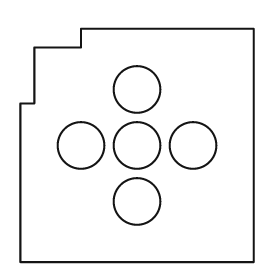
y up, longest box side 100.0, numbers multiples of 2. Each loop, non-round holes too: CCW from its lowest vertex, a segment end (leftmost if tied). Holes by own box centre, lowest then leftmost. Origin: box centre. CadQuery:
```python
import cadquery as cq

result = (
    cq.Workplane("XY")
    .moveTo(-50.0, -50.0)
    .lineTo(50.0, -50.0)
    .lineTo(50.0, 50.0)
    .lineTo(-24.0, 50.0)
    .lineTo(-24.0, 42.0)
    .lineTo(-44.0, 42.0)
    .lineTo(-44.0, 18.0)
    .lineTo(-50.0, 18.0)
    .close()
    .moveTo(0.0, -24.0)
    .circle(10.0)
    .moveTo(-24.0, 0.0)
    .circle(10.0)
    .moveTo(0.0, 0.0)
    .circle(10.0)
    .moveTo(24.0, 0.0)
    .circle(10.0)
    .moveTo(0.0, 24.0)
    .circle(10.0)
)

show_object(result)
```